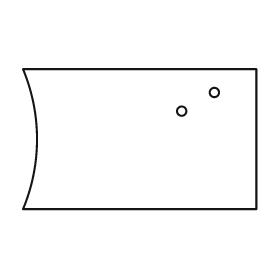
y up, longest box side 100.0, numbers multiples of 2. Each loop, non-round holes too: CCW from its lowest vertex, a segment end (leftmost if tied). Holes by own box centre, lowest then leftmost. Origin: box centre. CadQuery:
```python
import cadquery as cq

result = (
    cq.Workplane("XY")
    .moveTo(-50.0, -30.0)
    .lineTo(50.0, -30.0)
    .lineTo(50.0, 30.0)
    .lineTo(-50.0, 30.0)
    .threePointArc((-44.0, 0.0), (-50.0, -30.0))
    .close()
    .moveTo(18.0, 12.0)
    .circle(2.0)
    .moveTo(32.0, 20.0)
    .circle(2.0)
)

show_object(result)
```